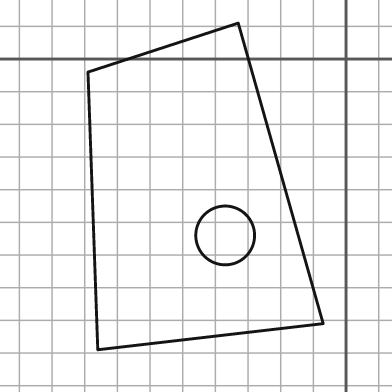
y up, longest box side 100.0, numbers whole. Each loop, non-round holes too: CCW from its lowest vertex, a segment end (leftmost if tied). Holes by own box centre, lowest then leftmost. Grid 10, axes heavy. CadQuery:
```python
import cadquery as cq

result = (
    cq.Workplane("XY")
    .moveTo(-76.0, -89.0)
    .lineTo(-7.0, -81.0)
    .lineTo(-33.0, 11.0)
    .lineTo(-79.0, -4.0)
    .close()
    .moveTo(-37.0, -54.0)
    .circle(9.0)
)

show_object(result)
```